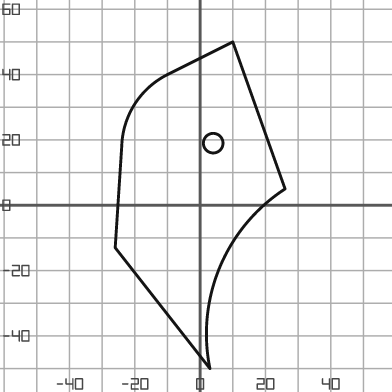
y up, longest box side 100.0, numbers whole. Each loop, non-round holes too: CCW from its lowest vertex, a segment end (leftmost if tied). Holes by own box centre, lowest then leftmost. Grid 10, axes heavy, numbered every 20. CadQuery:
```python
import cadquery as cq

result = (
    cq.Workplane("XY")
    .moveTo(3.0, -50.0)
    .threePointArc((6.0, -19.0), (26.0, 5.0))
    .lineTo(10.0, 50.0)
    .lineTo(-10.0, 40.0)
    .threePointArc((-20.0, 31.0), (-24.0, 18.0))
    .lineTo(-26.0, -13.0)
    .close()
    .moveTo(4.0, 19.0)
    .circle(3.0)
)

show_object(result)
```